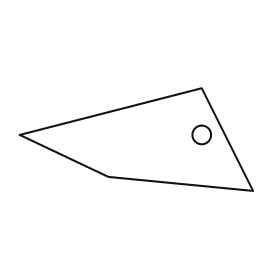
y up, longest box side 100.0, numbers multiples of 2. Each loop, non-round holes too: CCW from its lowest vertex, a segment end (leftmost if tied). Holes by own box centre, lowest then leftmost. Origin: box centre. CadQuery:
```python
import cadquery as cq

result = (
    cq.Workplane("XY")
    .moveTo(50.0, -22.0)
    .lineTo(28.0, 22.0)
    .lineTo(-50.0, 2.0)
    .lineTo(-12.0, -16.0)
    .close()
    .moveTo(28.0, 2.0)
    .circle(4.0)
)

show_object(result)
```